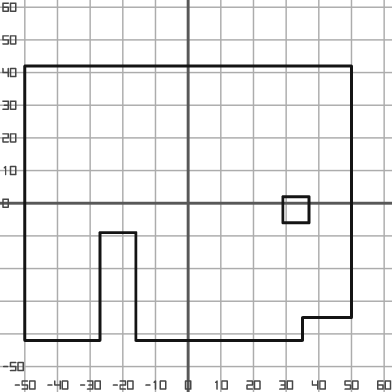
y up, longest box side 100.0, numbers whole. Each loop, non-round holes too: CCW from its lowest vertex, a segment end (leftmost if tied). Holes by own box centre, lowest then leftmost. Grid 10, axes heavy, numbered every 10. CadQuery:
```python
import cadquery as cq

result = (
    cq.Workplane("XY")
    .moveTo(-50.0, -42.0)
    .lineTo(-27.0, -42.0)
    .lineTo(-27.0, -9.0)
    .lineTo(-16.0, -9.0)
    .lineTo(-16.0, -42.0)
    .lineTo(35.0, -42.0)
    .lineTo(35.0, -35.0)
    .lineTo(50.0, -35.0)
    .lineTo(50.0, 42.0)
    .lineTo(-50.0, 42.0)
    .close()
    .moveTo(29.0, -6.0)
    .lineTo(37.0, -6.0)
    .lineTo(37.0, 2.0)
    .lineTo(29.0, 2.0)
    .close()
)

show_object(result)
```